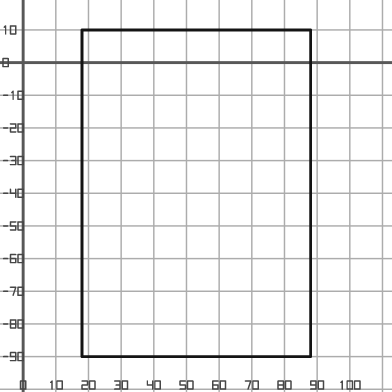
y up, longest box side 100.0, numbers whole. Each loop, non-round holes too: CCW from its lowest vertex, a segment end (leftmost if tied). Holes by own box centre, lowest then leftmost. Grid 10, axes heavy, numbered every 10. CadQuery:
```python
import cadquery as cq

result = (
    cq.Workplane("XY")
    .moveTo(18.0, -90.0)
    .lineTo(88.0, -90.0)
    .lineTo(88.0, 10.0)
    .lineTo(18.0, 10.0)
    .close()
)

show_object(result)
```